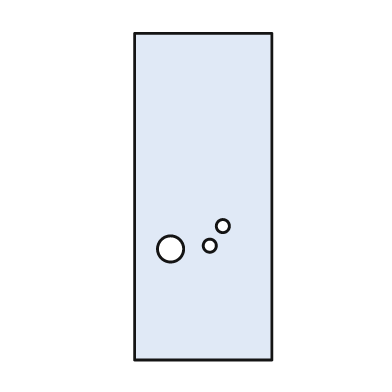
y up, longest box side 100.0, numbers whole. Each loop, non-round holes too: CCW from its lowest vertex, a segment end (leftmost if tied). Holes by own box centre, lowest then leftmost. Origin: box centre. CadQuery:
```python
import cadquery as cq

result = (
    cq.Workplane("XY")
    .moveTo(-21.0, -50.0)
    .lineTo(21.0, -50.0)
    .lineTo(21.0, 50.0)
    .lineTo(-21.0, 50.0)
    .close()
    .moveTo(-10.0, -16.0)
    .circle(4.0)
    .moveTo(2.0, -15.0)
    .circle(2.0)
    .moveTo(6.0, -9.0)
    .circle(2.0)
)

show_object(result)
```